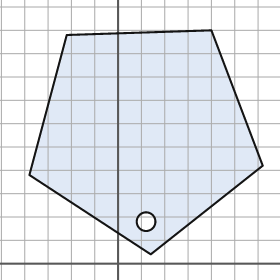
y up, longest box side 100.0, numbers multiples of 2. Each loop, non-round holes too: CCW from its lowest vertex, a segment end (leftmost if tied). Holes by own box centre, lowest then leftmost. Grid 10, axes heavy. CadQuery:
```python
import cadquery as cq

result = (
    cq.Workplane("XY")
    .moveTo(14.0, 4.0)
    .lineTo(62.0, 42.0)
    .lineTo(40.0, 100.0)
    .lineTo(-22.0, 98.0)
    .lineTo(-38.0, 38.0)
    .close()
    .moveTo(12.0, 18.0)
    .circle(4.0)
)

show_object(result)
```